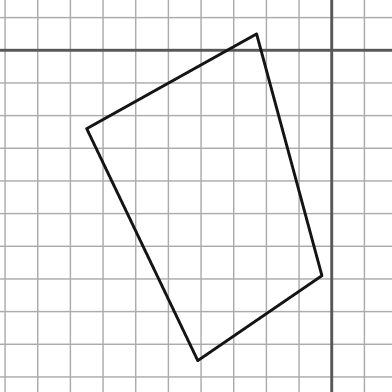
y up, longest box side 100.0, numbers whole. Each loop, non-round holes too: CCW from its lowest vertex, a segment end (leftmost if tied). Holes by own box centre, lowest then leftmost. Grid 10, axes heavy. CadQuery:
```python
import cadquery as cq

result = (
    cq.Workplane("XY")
    .moveTo(-41.0, -95.0)
    .lineTo(-3.0, -69.0)
    .lineTo(-23.0, 5.0)
    .lineTo(-75.0, -24.0)
    .close()
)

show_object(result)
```